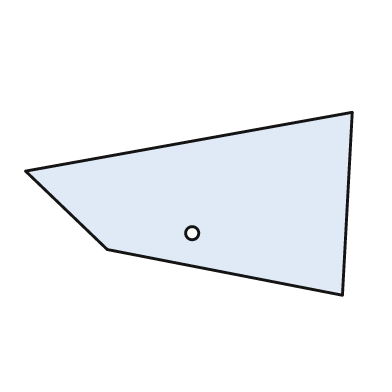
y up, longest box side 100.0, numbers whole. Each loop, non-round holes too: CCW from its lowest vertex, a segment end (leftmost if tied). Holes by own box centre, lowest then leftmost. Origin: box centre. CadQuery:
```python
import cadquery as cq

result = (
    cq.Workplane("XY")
    .moveTo(47.0, -28.0)
    .lineTo(50.0, 28.0)
    .lineTo(-50.0, 10.0)
    .lineTo(-25.0, -14.0)
    .close()
    .moveTo(1.0, -9.0)
    .circle(2.0)
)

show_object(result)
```